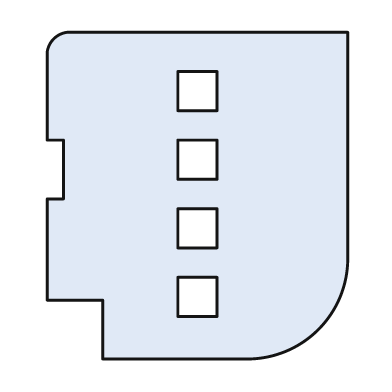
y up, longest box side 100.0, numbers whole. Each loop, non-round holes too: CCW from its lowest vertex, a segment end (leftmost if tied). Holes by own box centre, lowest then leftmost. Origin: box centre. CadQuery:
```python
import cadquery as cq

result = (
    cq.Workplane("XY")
    .moveTo(-29.0, -50.0)
    .lineTo(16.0, -50.0)
    .threePointArc((37.0, -41.0), (46.0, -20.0))
    .lineTo(46.0, 50.0)
    .lineTo(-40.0, 50.0)
    .threePointArc((-44.0, 48.0), (-46.0, 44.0))
    .lineTo(-46.0, 17.0)
    .lineTo(-41.0, 17.0)
    .lineTo(-41.0, -1.0)
    .lineTo(-46.0, -1.0)
    .lineTo(-46.0, -32.0)
    .lineTo(-29.0, -32.0)
    .close()
    .moveTo(-6.0, -37.0)
    .lineTo(6.0, -37.0)
    .lineTo(6.0, -25.0)
    .lineTo(-6.0, -25.0)
    .close()
    .moveTo(-6.0, -16.0)
    .lineTo(6.0, -16.0)
    .lineTo(6.0, -4.0)
    .lineTo(-6.0, -4.0)
    .close()
    .moveTo(-6.0, 5.0)
    .lineTo(6.0, 5.0)
    .lineTo(6.0, 17.0)
    .lineTo(-6.0, 17.0)
    .close()
    .moveTo(-6.0, 26.0)
    .lineTo(6.0, 26.0)
    .lineTo(6.0, 38.0)
    .lineTo(-6.0, 38.0)
    .close()
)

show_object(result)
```